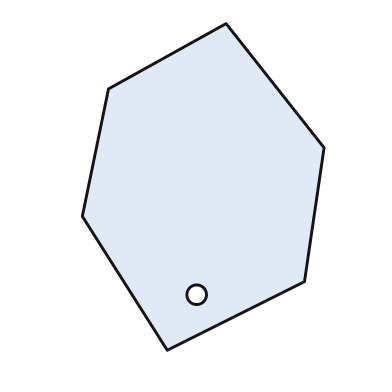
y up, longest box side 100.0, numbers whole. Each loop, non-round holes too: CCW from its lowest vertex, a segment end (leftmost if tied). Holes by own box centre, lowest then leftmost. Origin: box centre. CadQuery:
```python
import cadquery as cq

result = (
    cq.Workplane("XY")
    .moveTo(-11.0, -50.0)
    .lineTo(31.0, -29.0)
    .lineTo(37.0, 12.0)
    .lineTo(7.0, 50.0)
    .lineTo(-29.0, 30.0)
    .lineTo(-37.0, -9.0)
    .close()
    .moveTo(-2.0, -33.0)
    .circle(3.0)
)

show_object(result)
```